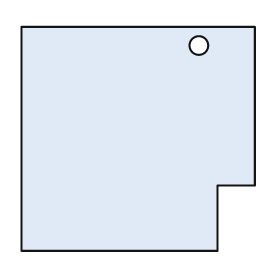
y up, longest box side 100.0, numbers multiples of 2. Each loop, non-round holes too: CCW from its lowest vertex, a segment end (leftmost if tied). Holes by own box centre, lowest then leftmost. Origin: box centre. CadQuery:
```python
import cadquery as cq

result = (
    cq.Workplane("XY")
    .moveTo(-50.0, -48.0)
    .lineTo(34.0, -48.0)
    .lineTo(34.0, -20.0)
    .lineTo(50.0, -20.0)
    .lineTo(50.0, 48.0)
    .lineTo(-50.0, 48.0)
    .close()
    .moveTo(26.0, 40.0)
    .circle(4.0)
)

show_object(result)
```